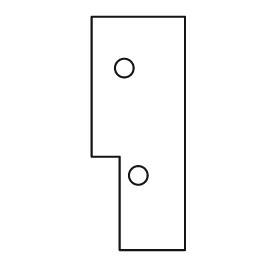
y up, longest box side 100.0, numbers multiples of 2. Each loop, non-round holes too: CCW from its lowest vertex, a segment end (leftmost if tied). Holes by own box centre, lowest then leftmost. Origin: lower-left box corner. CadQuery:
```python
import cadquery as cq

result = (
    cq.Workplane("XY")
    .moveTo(12.0, 0.0)
    .lineTo(40.0, 0.0)
    .lineTo(40.0, 100.0)
    .lineTo(0.0, 100.0)
    .lineTo(0.0, 40.0)
    .lineTo(12.0, 40.0)
    .close()
    .moveTo(20.0, 32.0)
    .circle(4.0)
    .moveTo(14.0, 78.0)
    .circle(4.0)
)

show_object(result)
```